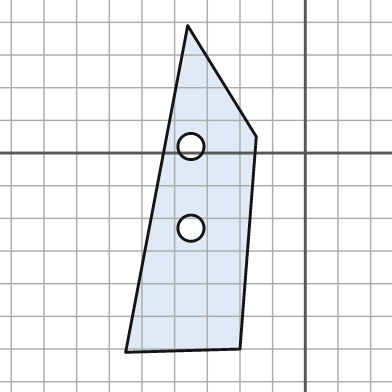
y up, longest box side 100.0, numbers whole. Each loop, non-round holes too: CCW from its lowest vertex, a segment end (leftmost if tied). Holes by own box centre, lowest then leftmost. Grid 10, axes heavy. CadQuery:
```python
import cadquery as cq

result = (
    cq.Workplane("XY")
    .moveTo(-55.0, -61.0)
    .lineTo(-20.0, -60.0)
    .lineTo(-15.0, 5.0)
    .lineTo(-36.0, 39.0)
    .close()
    .moveTo(-35.0, -23.0)
    .circle(4.0)
    .moveTo(-35.0, 2.0)
    .circle(4.0)
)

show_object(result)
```